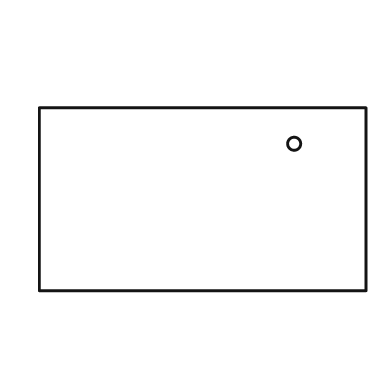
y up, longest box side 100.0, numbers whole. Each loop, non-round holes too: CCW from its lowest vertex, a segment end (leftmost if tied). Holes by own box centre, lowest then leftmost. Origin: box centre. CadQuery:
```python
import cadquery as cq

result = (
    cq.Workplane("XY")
    .moveTo(-50.0, -28.0)
    .lineTo(50.0, -28.0)
    .lineTo(50.0, 28.0)
    .lineTo(-50.0, 28.0)
    .close()
    .moveTo(28.0, 17.0)
    .circle(2.0)
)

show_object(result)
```